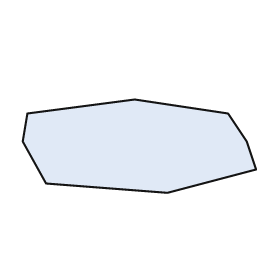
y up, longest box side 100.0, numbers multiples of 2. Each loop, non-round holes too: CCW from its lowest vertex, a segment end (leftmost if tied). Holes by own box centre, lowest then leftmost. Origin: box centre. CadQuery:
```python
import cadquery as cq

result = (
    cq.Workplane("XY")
    .moveTo(12.0, -20.0)
    .lineTo(50.0, -10.0)
    .lineTo(46.0, 2.0)
    .lineTo(38.0, 14.0)
    .lineTo(-2.0, 20.0)
    .lineTo(-48.0, 14.0)
    .lineTo(-50.0, 2.0)
    .lineTo(-40.0, -16.0)
    .close()
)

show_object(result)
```